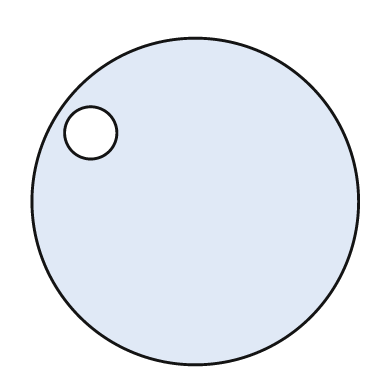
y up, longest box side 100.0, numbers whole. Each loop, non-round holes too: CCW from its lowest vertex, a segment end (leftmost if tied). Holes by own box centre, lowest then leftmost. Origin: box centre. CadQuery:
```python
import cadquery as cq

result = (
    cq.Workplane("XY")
    .moveTo(0.0, 0.0)
    .circle(50.0)
    .moveTo(-32.0, 21.0)
    .circle(8.0)
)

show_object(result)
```